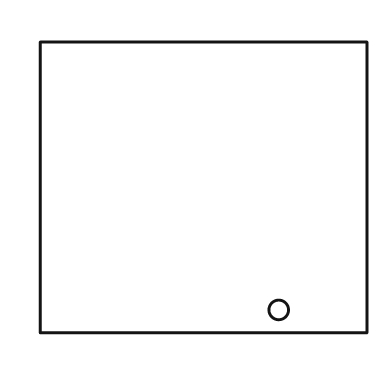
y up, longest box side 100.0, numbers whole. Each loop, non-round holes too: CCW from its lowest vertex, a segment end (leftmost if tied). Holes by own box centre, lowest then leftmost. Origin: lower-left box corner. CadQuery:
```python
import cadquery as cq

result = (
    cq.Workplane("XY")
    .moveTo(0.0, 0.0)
    .lineTo(100.0, 0.0)
    .lineTo(100.0, 89.0)
    .lineTo(0.0, 89.0)
    .close()
    .moveTo(73.0, 7.0)
    .circle(3.0)
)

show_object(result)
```